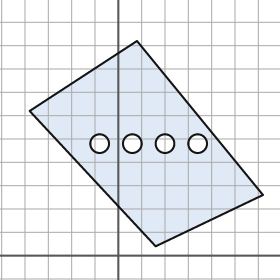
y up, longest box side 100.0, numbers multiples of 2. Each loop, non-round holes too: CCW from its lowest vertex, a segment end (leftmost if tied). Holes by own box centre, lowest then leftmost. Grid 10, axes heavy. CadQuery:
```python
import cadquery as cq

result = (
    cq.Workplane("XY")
    .moveTo(16.0, 4.0)
    .lineTo(62.0, 26.0)
    .lineTo(8.0, 92.0)
    .lineTo(-38.0, 62.0)
    .close()
    .moveTo(-8.0, 48.0)
    .circle(4.0)
    .moveTo(6.0, 48.0)
    .circle(4.0)
    .moveTo(20.0, 48.0)
    .circle(4.0)
    .moveTo(34.0, 48.0)
    .circle(4.0)
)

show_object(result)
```